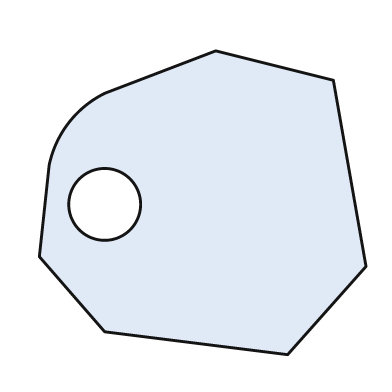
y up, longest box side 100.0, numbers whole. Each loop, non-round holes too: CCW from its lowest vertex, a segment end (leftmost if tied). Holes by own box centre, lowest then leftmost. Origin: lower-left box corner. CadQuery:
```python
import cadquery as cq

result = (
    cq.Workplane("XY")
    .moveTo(76.0, 0.0)
    .lineTo(100.0, 27.0)
    .lineTo(90.0, 84.0)
    .lineTo(54.0, 93.0)
    .lineTo(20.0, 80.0)
    .threePointArc((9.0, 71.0), (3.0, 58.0))
    .lineTo(0.0, 30.0)
    .lineTo(20.0, 7.0)
    .close()
    .moveTo(20.0, 46.0)
    .circle(11.0)
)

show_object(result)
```